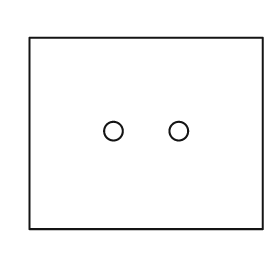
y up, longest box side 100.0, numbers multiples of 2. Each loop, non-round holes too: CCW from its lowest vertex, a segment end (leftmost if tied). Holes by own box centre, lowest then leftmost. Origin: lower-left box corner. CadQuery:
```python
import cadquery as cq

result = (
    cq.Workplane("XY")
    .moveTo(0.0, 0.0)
    .lineTo(100.0, 0.0)
    .lineTo(100.0, 82.0)
    .lineTo(0.0, 82.0)
    .close()
    .moveTo(36.0, 42.0)
    .circle(4.0)
    .moveTo(64.0, 42.0)
    .circle(4.0)
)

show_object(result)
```